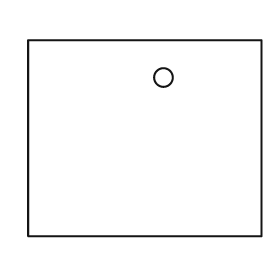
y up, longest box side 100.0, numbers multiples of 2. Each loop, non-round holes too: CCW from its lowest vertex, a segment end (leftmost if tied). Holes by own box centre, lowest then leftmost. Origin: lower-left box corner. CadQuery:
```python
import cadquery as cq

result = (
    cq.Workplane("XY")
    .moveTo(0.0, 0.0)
    .lineTo(100.0, 0.0)
    .lineTo(100.0, 84.0)
    .lineTo(0.0, 84.0)
    .close()
    .moveTo(58.0, 68.0)
    .circle(4.0)
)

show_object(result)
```